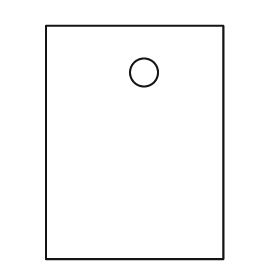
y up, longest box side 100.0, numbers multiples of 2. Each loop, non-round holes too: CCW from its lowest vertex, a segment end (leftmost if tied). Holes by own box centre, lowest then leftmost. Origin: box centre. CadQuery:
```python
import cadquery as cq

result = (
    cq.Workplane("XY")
    .moveTo(-38.0, -50.0)
    .lineTo(38.0, -50.0)
    .lineTo(38.0, 50.0)
    .lineTo(-38.0, 50.0)
    .close()
    .moveTo(4.0, 30.0)
    .circle(6.0)
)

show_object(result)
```